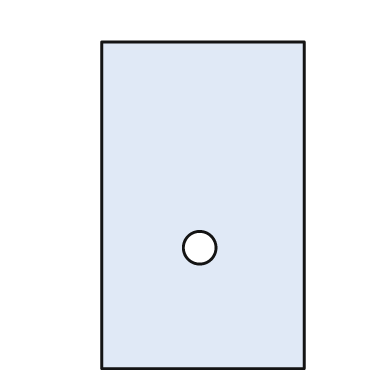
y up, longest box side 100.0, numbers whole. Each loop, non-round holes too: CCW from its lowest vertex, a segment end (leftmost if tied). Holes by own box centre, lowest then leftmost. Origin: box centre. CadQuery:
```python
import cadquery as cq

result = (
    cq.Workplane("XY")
    .moveTo(-31.0, -50.0)
    .lineTo(31.0, -50.0)
    .lineTo(31.0, 50.0)
    .lineTo(-31.0, 50.0)
    .close()
    .moveTo(-1.0, -13.0)
    .circle(5.0)
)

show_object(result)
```